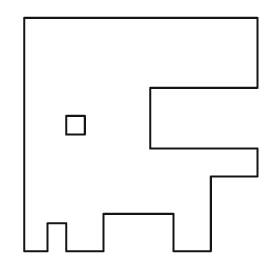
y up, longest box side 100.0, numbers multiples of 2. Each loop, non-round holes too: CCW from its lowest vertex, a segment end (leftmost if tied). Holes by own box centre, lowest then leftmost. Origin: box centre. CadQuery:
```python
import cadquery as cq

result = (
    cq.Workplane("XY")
    .moveTo(-50.0, -50.0)
    .lineTo(-40.0, -50.0)
    .lineTo(-40.0, -38.0)
    .lineTo(-32.0, -38.0)
    .lineTo(-32.0, -50.0)
    .lineTo(-16.0, -50.0)
    .lineTo(-16.0, -34.0)
    .lineTo(14.0, -34.0)
    .lineTo(14.0, -50.0)
    .lineTo(30.0, -50.0)
    .lineTo(30.0, -18.0)
    .lineTo(50.0, -18.0)
    .lineTo(50.0, -6.0)
    .lineTo(4.0, -6.0)
    .lineTo(4.0, 20.0)
    .lineTo(50.0, 20.0)
    .lineTo(50.0, 50.0)
    .lineTo(-50.0, 50.0)
    .close()
    .moveTo(-32.0, 0.0)
    .lineTo(-24.0, 0.0)
    .lineTo(-24.0, 8.0)
    .lineTo(-32.0, 8.0)
    .close()
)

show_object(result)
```